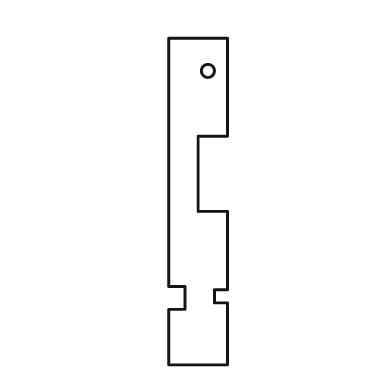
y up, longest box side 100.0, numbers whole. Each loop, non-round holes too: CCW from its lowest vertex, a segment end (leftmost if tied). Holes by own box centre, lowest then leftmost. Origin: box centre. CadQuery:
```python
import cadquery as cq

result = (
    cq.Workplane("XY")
    .moveTo(-9.0, -50.0)
    .lineTo(9.0, -50.0)
    .lineTo(9.0, -31.0)
    .lineTo(5.0, -31.0)
    .lineTo(5.0, -27.0)
    .lineTo(9.0, -27.0)
    .lineTo(9.0, -3.0)
    .lineTo(0.0, -3.0)
    .lineTo(0.0, 20.0)
    .lineTo(9.0, 20.0)
    .lineTo(9.0, 50.0)
    .lineTo(-9.0, 50.0)
    .lineTo(-9.0, -26.0)
    .lineTo(-4.0, -26.0)
    .lineTo(-4.0, -33.0)
    .lineTo(-9.0, -33.0)
    .close()
    .moveTo(3.0, 40.0)
    .circle(2.0)
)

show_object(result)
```